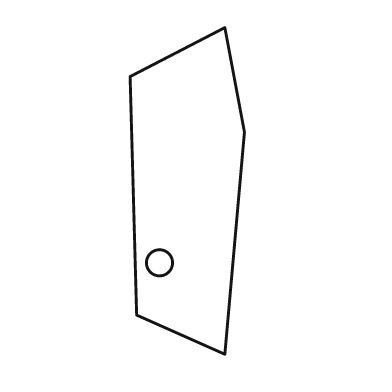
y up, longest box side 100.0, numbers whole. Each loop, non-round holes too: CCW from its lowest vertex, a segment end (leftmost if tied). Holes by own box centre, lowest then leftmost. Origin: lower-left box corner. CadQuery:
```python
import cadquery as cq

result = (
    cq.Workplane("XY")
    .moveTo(29.0, 0.0)
    .lineTo(35.0, 68.0)
    .lineTo(29.0, 100.0)
    .lineTo(0.0, 85.0)
    .lineTo(2.0, 12.0)
    .close()
    .moveTo(9.0, 28.0)
    .circle(4.0)
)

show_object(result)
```